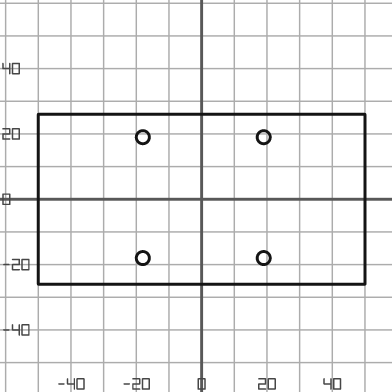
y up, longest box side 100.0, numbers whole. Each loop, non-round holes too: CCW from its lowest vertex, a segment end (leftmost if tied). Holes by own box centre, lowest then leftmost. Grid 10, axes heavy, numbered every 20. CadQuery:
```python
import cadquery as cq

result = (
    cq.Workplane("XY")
    .moveTo(-50.0, -26.0)
    .lineTo(50.0, -26.0)
    .lineTo(50.0, 26.0)
    .lineTo(-50.0, 26.0)
    .close()
    .moveTo(-18.0, -18.0)
    .circle(2.0)
    .moveTo(19.0, -18.0)
    .circle(2.0)
    .moveTo(-18.0, 19.0)
    .circle(2.0)
    .moveTo(19.0, 19.0)
    .circle(2.0)
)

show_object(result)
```